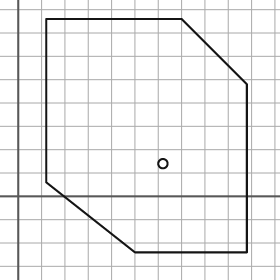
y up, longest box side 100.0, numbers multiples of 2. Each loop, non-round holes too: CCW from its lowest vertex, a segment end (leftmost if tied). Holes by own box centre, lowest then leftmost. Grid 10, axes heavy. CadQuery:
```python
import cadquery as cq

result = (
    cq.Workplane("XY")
    .moveTo(50.0, -24.0)
    .lineTo(98.0, -24.0)
    .lineTo(98.0, 48.0)
    .lineTo(70.0, 76.0)
    .lineTo(12.0, 76.0)
    .lineTo(12.0, 6.0)
    .close()
    .moveTo(62.0, 14.0)
    .circle(2.0)
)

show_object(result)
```